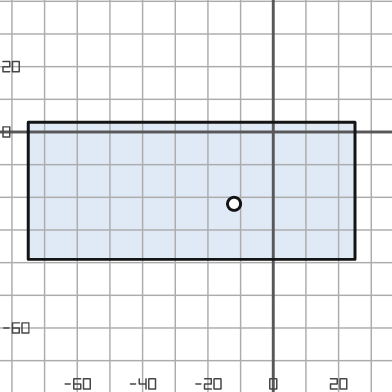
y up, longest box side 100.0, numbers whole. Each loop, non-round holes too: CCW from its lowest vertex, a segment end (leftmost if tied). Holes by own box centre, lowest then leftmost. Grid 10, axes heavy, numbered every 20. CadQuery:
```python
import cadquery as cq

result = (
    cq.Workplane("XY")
    .moveTo(-75.0, -39.0)
    .lineTo(25.0, -39.0)
    .lineTo(25.0, 3.0)
    .lineTo(-75.0, 3.0)
    .close()
    .moveTo(-12.0, -22.0)
    .circle(2.0)
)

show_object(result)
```